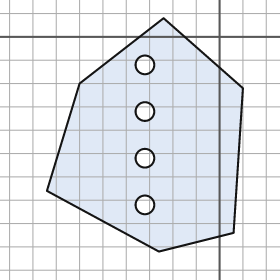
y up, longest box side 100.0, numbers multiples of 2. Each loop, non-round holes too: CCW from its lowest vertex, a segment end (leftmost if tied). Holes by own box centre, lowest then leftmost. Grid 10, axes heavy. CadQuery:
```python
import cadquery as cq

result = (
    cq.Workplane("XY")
    .moveTo(-26.0, -92.0)
    .lineTo(6.0, -84.0)
    .lineTo(10.0, -22.0)
    .lineTo(-24.0, 8.0)
    .lineTo(-60.0, -20.0)
    .lineTo(-74.0, -66.0)
    .close()
    .moveTo(-32.0, -72.0)
    .circle(4.0)
    .moveTo(-32.0, -52.0)
    .circle(4.0)
    .moveTo(-32.0, -32.0)
    .circle(4.0)
    .moveTo(-32.0, -12.0)
    .circle(4.0)
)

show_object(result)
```